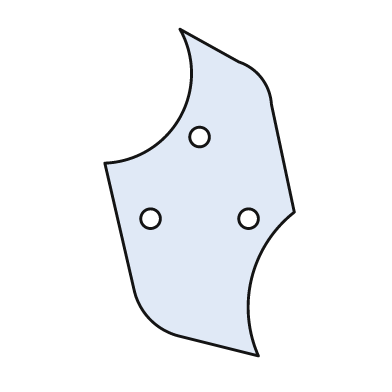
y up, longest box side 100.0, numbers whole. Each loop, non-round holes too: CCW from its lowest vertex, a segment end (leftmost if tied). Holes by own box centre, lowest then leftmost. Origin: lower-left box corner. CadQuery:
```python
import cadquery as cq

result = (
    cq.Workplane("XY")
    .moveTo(47.0, 0.0)
    .threePointArc((45.0, 24.0), (58.0, 44.0))
    .lineTo(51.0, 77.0)
    .threePointArc((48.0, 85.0), (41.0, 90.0))
    .lineTo(23.0, 100.0)
    .threePointArc((23.0, 73.0), (0.0, 59.0))
    .lineTo(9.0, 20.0)
    .threePointArc((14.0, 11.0), (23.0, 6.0))
    .close()
    .moveTo(14.0, 42.0)
    .circle(3.0)
    .moveTo(44.0, 42.0)
    .circle(3.0)
    .moveTo(29.0, 67.0)
    .circle(3.0)
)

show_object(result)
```